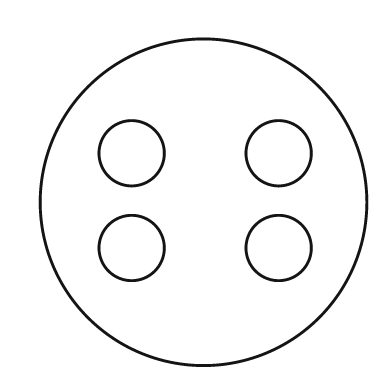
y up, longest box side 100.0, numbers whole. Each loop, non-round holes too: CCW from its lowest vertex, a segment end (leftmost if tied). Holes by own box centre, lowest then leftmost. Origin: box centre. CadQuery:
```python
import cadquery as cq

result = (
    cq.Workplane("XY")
    .moveTo(0.0, 0.0)
    .circle(50.0)
    .moveTo(-22.0, -14.0)
    .circle(10.0)
    .moveTo(23.0, -14.0)
    .circle(10.0)
    .moveTo(-22.0, 15.0)
    .circle(10.0)
    .moveTo(23.0, 15.0)
    .circle(10.0)
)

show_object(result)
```